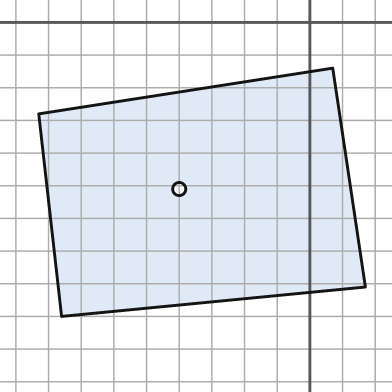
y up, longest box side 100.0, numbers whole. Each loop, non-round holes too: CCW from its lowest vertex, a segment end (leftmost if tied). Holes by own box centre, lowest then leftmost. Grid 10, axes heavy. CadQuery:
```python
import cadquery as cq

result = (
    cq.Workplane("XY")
    .moveTo(-76.0, -90.0)
    .lineTo(17.0, -81.0)
    .lineTo(7.0, -14.0)
    .lineTo(-83.0, -28.0)
    .close()
    .moveTo(-40.0, -51.0)
    .circle(2.0)
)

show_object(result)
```